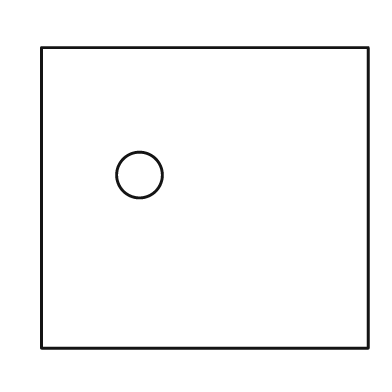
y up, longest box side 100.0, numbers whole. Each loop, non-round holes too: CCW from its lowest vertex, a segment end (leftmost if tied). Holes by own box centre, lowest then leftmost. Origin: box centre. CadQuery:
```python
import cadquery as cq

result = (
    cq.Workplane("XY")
    .moveTo(-50.0, -46.0)
    .lineTo(50.0, -46.0)
    .lineTo(50.0, 46.0)
    .lineTo(-50.0, 46.0)
    .close()
    .moveTo(-20.0, 7.0)
    .circle(7.0)
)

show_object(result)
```